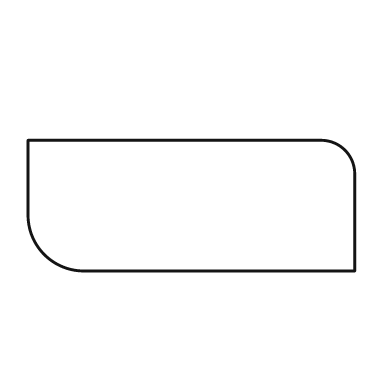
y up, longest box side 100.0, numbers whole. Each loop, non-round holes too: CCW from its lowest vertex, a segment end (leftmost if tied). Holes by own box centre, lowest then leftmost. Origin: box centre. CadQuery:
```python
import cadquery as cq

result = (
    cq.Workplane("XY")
    .moveTo(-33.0, -20.0)
    .lineTo(50.0, -20.0)
    .lineTo(50.0, 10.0)
    .threePointArc((47.0, 17.0), (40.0, 20.0))
    .lineTo(-50.0, 20.0)
    .lineTo(-50.0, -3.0)
    .threePointArc((-45.0, -15.0), (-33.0, -20.0))
    .close()
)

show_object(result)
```